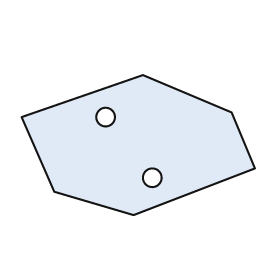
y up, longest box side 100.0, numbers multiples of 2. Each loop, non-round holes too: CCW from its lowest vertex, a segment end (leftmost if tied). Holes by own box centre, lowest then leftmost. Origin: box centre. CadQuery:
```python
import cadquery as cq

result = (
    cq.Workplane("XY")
    .moveTo(-2.0, -30.0)
    .lineTo(50.0, -10.0)
    .lineTo(40.0, 14.0)
    .lineTo(2.0, 30.0)
    .lineTo(-50.0, 12.0)
    .lineTo(-36.0, -20.0)
    .close()
    .moveTo(6.0, -14.0)
    .circle(4.0)
    .moveTo(-14.0, 12.0)
    .circle(4.0)
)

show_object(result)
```